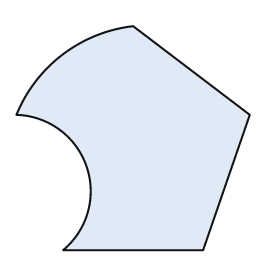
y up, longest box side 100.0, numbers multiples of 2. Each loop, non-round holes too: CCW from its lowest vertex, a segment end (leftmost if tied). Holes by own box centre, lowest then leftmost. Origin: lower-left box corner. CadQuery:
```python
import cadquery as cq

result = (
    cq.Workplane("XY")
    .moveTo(20.0, 0.0)
    .lineTo(80.0, 0.0)
    .lineTo(100.0, 58.0)
    .lineTo(50.0, 96.0)
    .threePointArc((20.0, 84.0), (0.0, 58.0))
    .threePointArc((30.0, 36.0), (20.0, 0.0))
    .close()
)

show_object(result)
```